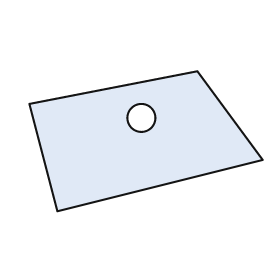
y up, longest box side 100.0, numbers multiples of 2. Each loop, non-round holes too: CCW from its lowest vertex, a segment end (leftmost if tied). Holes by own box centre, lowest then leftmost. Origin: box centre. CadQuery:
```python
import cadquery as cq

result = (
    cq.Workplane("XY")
    .moveTo(-38.0, -30.0)
    .lineTo(50.0, -8.0)
    .lineTo(22.0, 30.0)
    .lineTo(-50.0, 16.0)
    .close()
    .moveTo(-2.0, 10.0)
    .circle(6.0)
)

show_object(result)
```